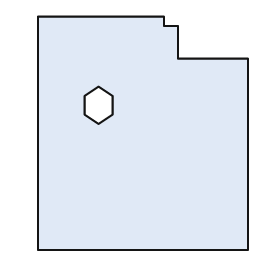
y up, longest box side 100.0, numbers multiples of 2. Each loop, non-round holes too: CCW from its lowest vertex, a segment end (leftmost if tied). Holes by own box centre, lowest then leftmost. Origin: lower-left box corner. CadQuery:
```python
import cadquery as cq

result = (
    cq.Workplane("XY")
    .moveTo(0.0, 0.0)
    .lineTo(90.0, 0.0)
    .lineTo(90.0, 82.0)
    .lineTo(60.0, 82.0)
    .lineTo(60.0, 96.0)
    .lineTo(54.0, 96.0)
    .lineTo(54.0, 100.0)
    .lineTo(0.0, 100.0)
    .close()
    .moveTo(26.0, 54.0)
    .lineTo(32.0, 58.0)
    .lineTo(32.0, 66.0)
    .lineTo(26.0, 70.0)
    .lineTo(20.0, 66.0)
    .lineTo(20.0, 58.0)
    .close()
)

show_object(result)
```